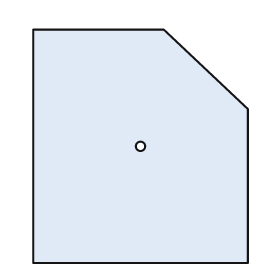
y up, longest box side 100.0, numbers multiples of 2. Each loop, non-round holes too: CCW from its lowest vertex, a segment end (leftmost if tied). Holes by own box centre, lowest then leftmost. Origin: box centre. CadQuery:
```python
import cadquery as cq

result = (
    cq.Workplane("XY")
    .moveTo(-46.0, -50.0)
    .lineTo(46.0, -50.0)
    .lineTo(46.0, 16.0)
    .lineTo(10.0, 50.0)
    .lineTo(-46.0, 50.0)
    .close()
    .moveTo(0.0, 0.0)
    .circle(2.0)
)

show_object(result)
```